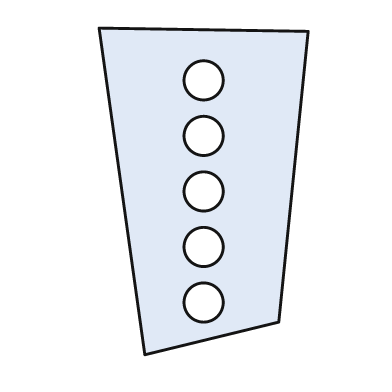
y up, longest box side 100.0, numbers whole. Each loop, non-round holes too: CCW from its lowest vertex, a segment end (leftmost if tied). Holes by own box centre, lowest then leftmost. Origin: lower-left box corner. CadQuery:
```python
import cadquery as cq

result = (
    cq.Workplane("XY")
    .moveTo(14.0, 0.0)
    .lineTo(55.0, 10.0)
    .lineTo(64.0, 99.0)
    .lineTo(0.0, 100.0)
    .close()
    .moveTo(32.0, 16.0)
    .circle(6.0)
    .moveTo(32.0, 33.0)
    .circle(6.0)
    .moveTo(32.0, 50.0)
    .circle(6.0)
    .moveTo(32.0, 67.0)
    .circle(6.0)
    .moveTo(32.0, 84.0)
    .circle(6.0)
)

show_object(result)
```